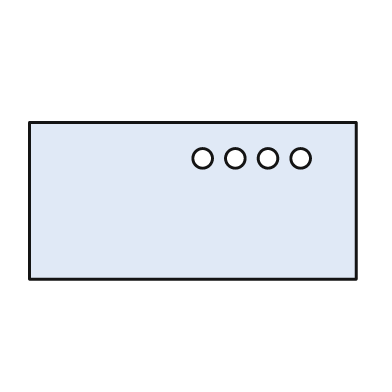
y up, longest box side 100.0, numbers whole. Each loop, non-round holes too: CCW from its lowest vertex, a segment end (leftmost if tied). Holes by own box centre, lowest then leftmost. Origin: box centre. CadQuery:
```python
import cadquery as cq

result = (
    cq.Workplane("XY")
    .moveTo(-50.0, -24.0)
    .lineTo(50.0, -24.0)
    .lineTo(50.0, 24.0)
    .lineTo(-50.0, 24.0)
    .close()
    .moveTo(3.0, 13.0)
    .circle(3.0)
    .moveTo(13.0, 13.0)
    .circle(3.0)
    .moveTo(23.0, 13.0)
    .circle(3.0)
    .moveTo(33.0, 13.0)
    .circle(3.0)
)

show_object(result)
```